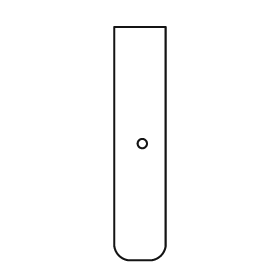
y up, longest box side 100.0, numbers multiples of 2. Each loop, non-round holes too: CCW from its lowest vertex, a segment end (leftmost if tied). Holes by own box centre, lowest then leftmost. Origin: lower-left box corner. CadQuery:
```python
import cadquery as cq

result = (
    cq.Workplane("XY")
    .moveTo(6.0, 0.0)
    .lineTo(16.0, 0.0)
    .threePointArc((20.0, 2.0), (22.0, 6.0))
    .lineTo(22.0, 100.0)
    .lineTo(0.0, 100.0)
    .lineTo(0.0, 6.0)
    .threePointArc((2.0, 2.0), (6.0, 0.0))
    .close()
    .moveTo(12.0, 50.0)
    .circle(2.0)
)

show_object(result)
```